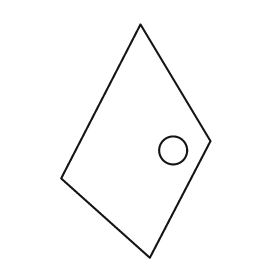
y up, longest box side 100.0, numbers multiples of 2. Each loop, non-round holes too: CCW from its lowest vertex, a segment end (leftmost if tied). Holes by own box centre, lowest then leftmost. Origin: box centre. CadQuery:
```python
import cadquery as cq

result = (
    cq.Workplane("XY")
    .moveTo(6.0, -50.0)
    .lineTo(32.0, 0.0)
    .lineTo(2.0, 50.0)
    .lineTo(-32.0, -16.0)
    .close()
    .moveTo(16.0, -4.0)
    .circle(6.0)
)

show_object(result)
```